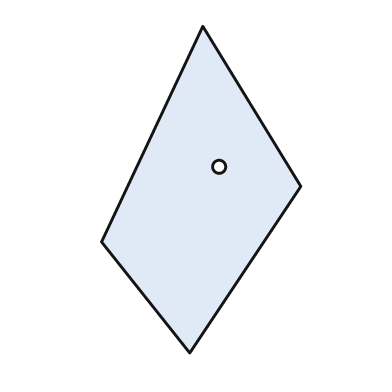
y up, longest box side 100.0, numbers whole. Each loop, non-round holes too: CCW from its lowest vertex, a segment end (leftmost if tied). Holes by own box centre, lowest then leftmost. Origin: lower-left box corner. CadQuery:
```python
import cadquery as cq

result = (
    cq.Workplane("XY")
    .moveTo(27.0, 0.0)
    .lineTo(61.0, 51.0)
    .lineTo(31.0, 100.0)
    .lineTo(0.0, 34.0)
    .close()
    .moveTo(36.0, 57.0)
    .circle(2.0)
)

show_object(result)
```